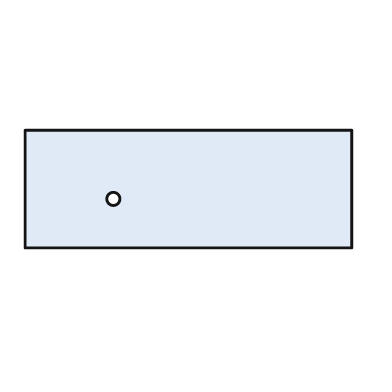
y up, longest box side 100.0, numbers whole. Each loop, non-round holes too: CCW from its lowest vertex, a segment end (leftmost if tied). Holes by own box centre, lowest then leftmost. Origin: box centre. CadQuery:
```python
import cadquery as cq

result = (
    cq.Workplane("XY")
    .moveTo(-50.0, -18.0)
    .lineTo(50.0, -18.0)
    .lineTo(50.0, 18.0)
    .lineTo(-50.0, 18.0)
    .close()
    .moveTo(-23.0, -3.0)
    .circle(2.0)
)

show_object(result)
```